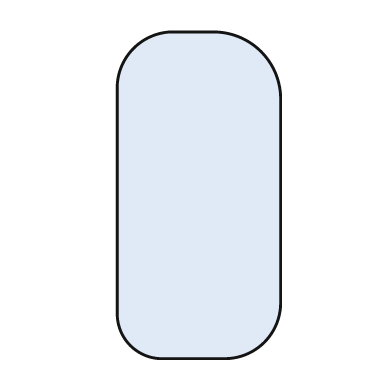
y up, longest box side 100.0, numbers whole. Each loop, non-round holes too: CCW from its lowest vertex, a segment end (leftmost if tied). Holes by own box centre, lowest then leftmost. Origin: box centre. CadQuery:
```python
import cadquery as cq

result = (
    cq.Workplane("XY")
    .moveTo(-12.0, -50.0)
    .lineTo(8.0, -50.0)
    .threePointArc((20.0, -45.0), (25.0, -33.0))
    .lineTo(25.0, 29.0)
    .threePointArc((19.0, 44.0), (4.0, 50.0))
    .lineTo(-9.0, 50.0)
    .threePointArc((-20.0, 45.0), (-25.0, 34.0))
    .lineTo(-25.0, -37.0)
    .threePointArc((-21.0, -46.0), (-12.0, -50.0))
    .close()
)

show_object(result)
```